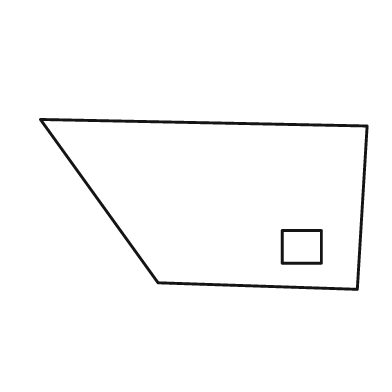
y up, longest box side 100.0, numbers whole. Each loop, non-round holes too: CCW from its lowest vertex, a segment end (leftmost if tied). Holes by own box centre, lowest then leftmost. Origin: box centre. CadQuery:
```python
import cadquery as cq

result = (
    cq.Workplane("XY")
    .moveTo(47.0, -26.0)
    .lineTo(50.0, 24.0)
    .lineTo(-50.0, 26.0)
    .lineTo(-14.0, -24.0)
    .close()
    .moveTo(24.0, -18.0)
    .lineTo(36.0, -18.0)
    .lineTo(36.0, -8.0)
    .lineTo(24.0, -8.0)
    .close()
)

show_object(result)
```